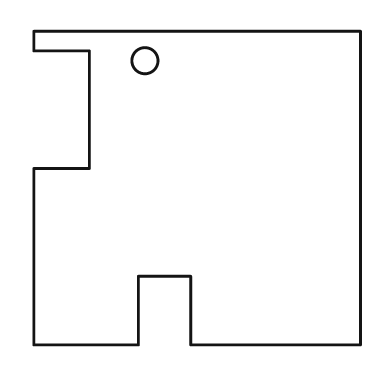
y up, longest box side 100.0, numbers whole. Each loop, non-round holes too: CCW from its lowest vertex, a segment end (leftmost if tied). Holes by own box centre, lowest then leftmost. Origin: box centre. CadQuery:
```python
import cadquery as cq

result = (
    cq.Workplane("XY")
    .moveTo(-50.0, -48.0)
    .lineTo(-18.0, -48.0)
    .lineTo(-18.0, -27.0)
    .lineTo(-2.0, -27.0)
    .lineTo(-2.0, -48.0)
    .lineTo(50.0, -48.0)
    .lineTo(50.0, 48.0)
    .lineTo(-50.0, 48.0)
    .lineTo(-50.0, 42.0)
    .lineTo(-33.0, 42.0)
    .lineTo(-33.0, 6.0)
    .lineTo(-50.0, 6.0)
    .close()
    .moveTo(-16.0, 39.0)
    .circle(4.0)
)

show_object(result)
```